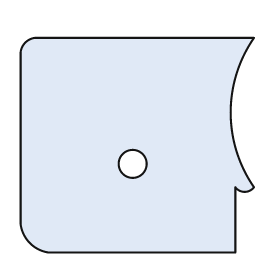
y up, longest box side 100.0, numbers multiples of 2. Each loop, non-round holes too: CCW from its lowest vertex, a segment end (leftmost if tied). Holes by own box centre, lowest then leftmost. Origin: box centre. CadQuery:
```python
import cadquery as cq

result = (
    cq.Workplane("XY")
    .moveTo(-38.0, -46.0)
    .lineTo(42.0, -46.0)
    .lineTo(42.0, -18.0)
    .threePointArc((46.0, -20.0), (50.0, -18.0))
    .threePointArc((40.0, 14.0), (50.0, 46.0))
    .lineTo(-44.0, 46.0)
    .threePointArc((-48.0, 44.0), (-50.0, 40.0))
    .lineTo(-50.0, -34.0)
    .threePointArc((-46.0, -42.0), (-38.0, -46.0))
    .close()
    .moveTo(-2.0, -8.0)
    .circle(6.0)
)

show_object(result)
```